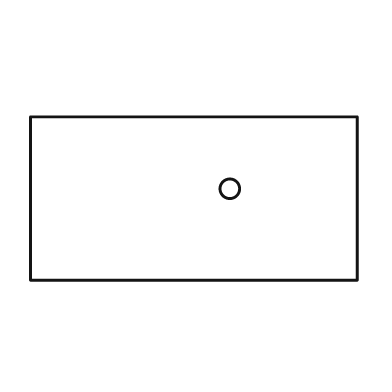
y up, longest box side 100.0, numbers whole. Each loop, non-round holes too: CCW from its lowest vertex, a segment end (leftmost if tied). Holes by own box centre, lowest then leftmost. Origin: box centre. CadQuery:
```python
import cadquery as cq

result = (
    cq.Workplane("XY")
    .moveTo(-50.0, -25.0)
    .lineTo(50.0, -25.0)
    .lineTo(50.0, 25.0)
    .lineTo(-50.0, 25.0)
    .close()
    .moveTo(11.0, 3.0)
    .circle(3.0)
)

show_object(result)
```